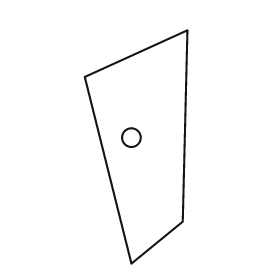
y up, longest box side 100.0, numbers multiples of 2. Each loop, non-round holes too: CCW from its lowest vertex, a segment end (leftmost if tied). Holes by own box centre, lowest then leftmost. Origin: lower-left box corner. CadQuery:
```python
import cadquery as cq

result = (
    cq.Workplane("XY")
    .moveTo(20.0, 0.0)
    .lineTo(42.0, 18.0)
    .lineTo(44.0, 100.0)
    .lineTo(0.0, 80.0)
    .close()
    .moveTo(20.0, 54.0)
    .circle(4.0)
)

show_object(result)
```